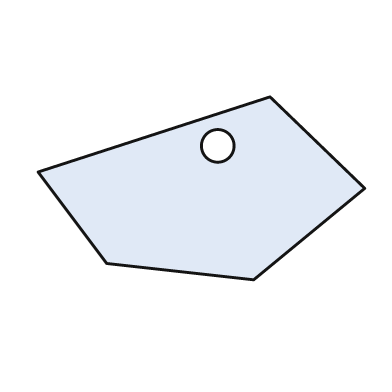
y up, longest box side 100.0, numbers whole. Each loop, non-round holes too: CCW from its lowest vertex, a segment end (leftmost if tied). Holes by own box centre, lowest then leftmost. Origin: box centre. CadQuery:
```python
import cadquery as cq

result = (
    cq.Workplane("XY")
    .moveTo(16.0, -28.0)
    .lineTo(50.0, 0.0)
    .lineTo(21.0, 28.0)
    .lineTo(-50.0, 5.0)
    .lineTo(-29.0, -23.0)
    .close()
    .moveTo(5.0, 13.0)
    .circle(5.0)
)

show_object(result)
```